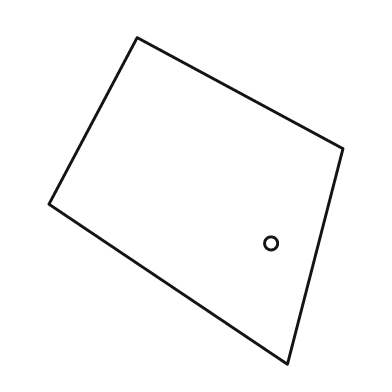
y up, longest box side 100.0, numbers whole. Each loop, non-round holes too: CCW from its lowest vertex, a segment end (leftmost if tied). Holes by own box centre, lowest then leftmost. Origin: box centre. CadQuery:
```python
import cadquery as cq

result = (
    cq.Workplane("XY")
    .moveTo(28.0, -50.0)
    .lineTo(45.0, 16.0)
    .lineTo(-18.0, 50.0)
    .lineTo(-45.0, -1.0)
    .close()
    .moveTo(23.0, -13.0)
    .circle(2.0)
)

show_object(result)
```